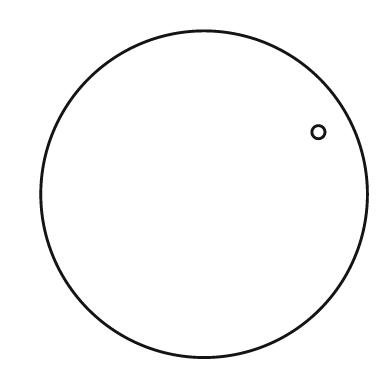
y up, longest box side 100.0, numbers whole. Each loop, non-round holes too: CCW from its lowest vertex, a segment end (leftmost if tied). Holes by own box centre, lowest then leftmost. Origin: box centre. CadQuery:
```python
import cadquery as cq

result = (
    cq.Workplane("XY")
    .moveTo(0.0, 0.0)
    .circle(50.0)
    .moveTo(35.0, 19.0)
    .circle(2.0)
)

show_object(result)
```